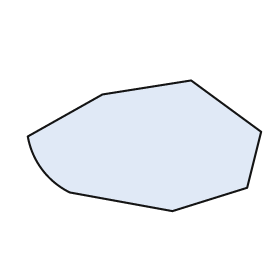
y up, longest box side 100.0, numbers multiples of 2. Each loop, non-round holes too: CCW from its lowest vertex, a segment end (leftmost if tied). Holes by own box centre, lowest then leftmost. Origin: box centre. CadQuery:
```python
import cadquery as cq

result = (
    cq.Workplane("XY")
    .moveTo(12.0, -28.0)
    .lineTo(44.0, -18.0)
    .lineTo(50.0, 6.0)
    .lineTo(20.0, 28.0)
    .lineTo(-18.0, 22.0)
    .lineTo(-50.0, 4.0)
    .threePointArc((-44.0, -10.0), (-32.0, -20.0))
    .close()
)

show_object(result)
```